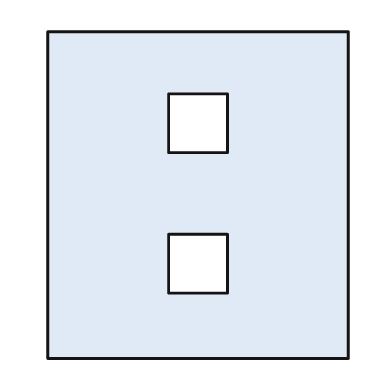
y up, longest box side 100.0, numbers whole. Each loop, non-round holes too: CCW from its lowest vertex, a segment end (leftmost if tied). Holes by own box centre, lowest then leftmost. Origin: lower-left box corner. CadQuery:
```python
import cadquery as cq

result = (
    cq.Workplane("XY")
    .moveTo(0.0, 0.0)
    .lineTo(92.0, 0.0)
    .lineTo(92.0, 100.0)
    .lineTo(0.0, 100.0)
    .close()
    .moveTo(37.0, 20.0)
    .lineTo(55.0, 20.0)
    .lineTo(55.0, 38.0)
    .lineTo(37.0, 38.0)
    .close()
    .moveTo(37.0, 63.0)
    .lineTo(55.0, 63.0)
    .lineTo(55.0, 81.0)
    .lineTo(37.0, 81.0)
    .close()
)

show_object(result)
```